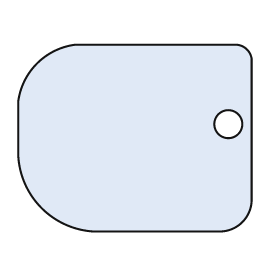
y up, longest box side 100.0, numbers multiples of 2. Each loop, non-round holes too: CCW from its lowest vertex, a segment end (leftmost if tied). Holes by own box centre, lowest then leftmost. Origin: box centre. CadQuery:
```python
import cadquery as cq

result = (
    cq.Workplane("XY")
    .moveTo(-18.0, -40.0)
    .lineTo(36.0, -40.0)
    .threePointArc((46.0, -36.0), (50.0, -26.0))
    .lineTo(50.0, 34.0)
    .threePointArc((48.0, 38.0), (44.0, 40.0))
    .lineTo(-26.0, 40.0)
    .threePointArc((-42.0, 32.0), (-50.0, 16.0))
    .lineTo(-50.0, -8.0)
    .threePointArc((-40.0, -30.0), (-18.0, -40.0))
    .close()
    .moveTo(40.0, 6.0)
    .circle(6.0)
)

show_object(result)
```